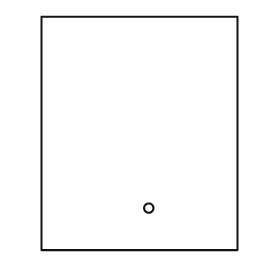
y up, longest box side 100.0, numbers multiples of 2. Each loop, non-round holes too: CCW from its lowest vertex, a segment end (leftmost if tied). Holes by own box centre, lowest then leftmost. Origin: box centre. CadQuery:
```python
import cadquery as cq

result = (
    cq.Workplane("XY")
    .moveTo(-42.0, -50.0)
    .lineTo(42.0, -50.0)
    .lineTo(42.0, 50.0)
    .lineTo(-42.0, 50.0)
    .close()
    .moveTo(4.0, -32.0)
    .circle(2.0)
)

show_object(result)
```